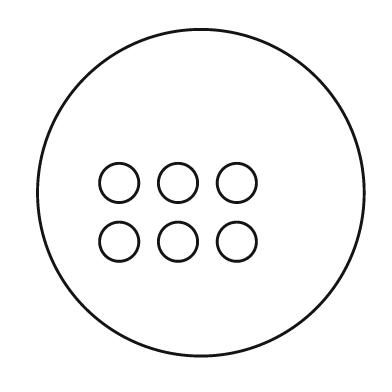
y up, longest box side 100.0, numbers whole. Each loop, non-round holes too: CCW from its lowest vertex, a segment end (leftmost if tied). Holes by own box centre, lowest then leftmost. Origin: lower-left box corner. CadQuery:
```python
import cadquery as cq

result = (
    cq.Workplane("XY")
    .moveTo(50.0, 50.0)
    .circle(50.0)
    .moveTo(25.0, 35.0)
    .circle(6.0)
    .moveTo(43.0, 35.0)
    .circle(6.0)
    .moveTo(61.0, 35.0)
    .circle(6.0)
    .moveTo(25.0, 53.0)
    .circle(6.0)
    .moveTo(43.0, 53.0)
    .circle(6.0)
    .moveTo(61.0, 53.0)
    .circle(6.0)
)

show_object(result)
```